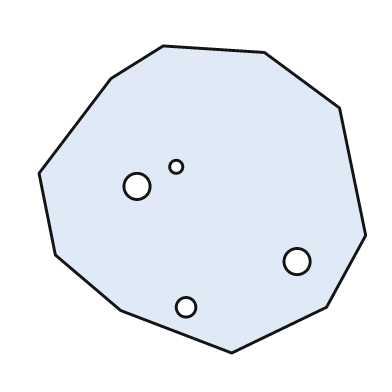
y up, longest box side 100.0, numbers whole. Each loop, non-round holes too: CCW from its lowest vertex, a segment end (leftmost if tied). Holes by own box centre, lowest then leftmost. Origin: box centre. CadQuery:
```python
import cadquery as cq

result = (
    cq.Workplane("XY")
    .moveTo(9.0, -47.0)
    .lineTo(38.0, -33.0)
    .lineTo(50.0, -11.0)
    .lineTo(42.0, 28.0)
    .lineTo(19.0, 45.0)
    .lineTo(-12.0, 47.0)
    .lineTo(-28.0, 37.0)
    .lineTo(-50.0, 8.0)
    .lineTo(-45.0, -17.0)
    .lineTo(-25.0, -34.0)
    .close()
    .moveTo(-5.0, -33.0)
    .circle(3.0)
    .moveTo(29.0, -19.0)
    .circle(4.0)
    .moveTo(-20.0, 4.0)
    .circle(4.0)
    .moveTo(-8.0, 10.0)
    .circle(2.0)
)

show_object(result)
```